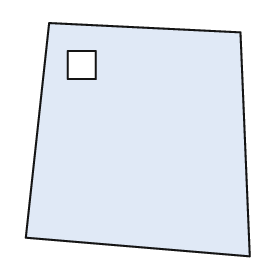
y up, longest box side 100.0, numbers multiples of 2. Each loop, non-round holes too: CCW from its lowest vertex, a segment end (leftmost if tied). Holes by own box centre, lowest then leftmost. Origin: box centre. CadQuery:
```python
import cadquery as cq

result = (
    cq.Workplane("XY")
    .moveTo(48.0, -50.0)
    .lineTo(44.0, 46.0)
    .lineTo(-38.0, 50.0)
    .lineTo(-48.0, -42.0)
    .close()
    .moveTo(-30.0, 26.0)
    .lineTo(-18.0, 26.0)
    .lineTo(-18.0, 38.0)
    .lineTo(-30.0, 38.0)
    .close()
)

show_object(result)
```